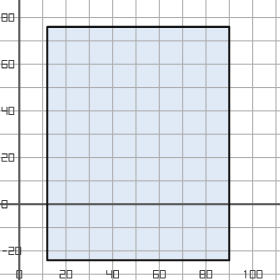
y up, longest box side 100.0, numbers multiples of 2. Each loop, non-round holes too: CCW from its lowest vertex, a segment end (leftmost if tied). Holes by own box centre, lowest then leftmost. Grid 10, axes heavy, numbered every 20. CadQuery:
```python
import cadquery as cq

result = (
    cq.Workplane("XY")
    .moveTo(12.0, -24.0)
    .lineTo(90.0, -24.0)
    .lineTo(90.0, 76.0)
    .lineTo(12.0, 76.0)
    .close()
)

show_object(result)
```